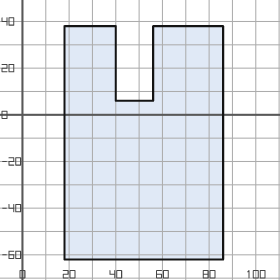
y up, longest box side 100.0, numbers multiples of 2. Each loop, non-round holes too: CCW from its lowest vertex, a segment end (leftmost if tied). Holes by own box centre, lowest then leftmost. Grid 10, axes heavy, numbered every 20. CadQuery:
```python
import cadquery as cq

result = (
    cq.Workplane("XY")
    .moveTo(18.0, -62.0)
    .lineTo(86.0, -62.0)
    .lineTo(86.0, 38.0)
    .lineTo(56.0, 38.0)
    .lineTo(56.0, 6.0)
    .lineTo(40.0, 6.0)
    .lineTo(40.0, 38.0)
    .lineTo(18.0, 38.0)
    .close()
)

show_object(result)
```